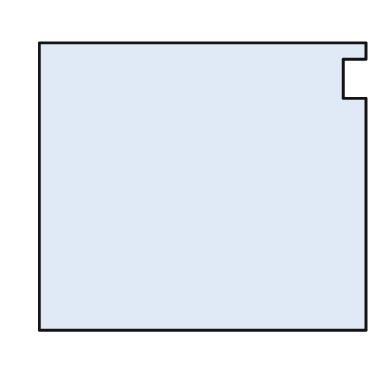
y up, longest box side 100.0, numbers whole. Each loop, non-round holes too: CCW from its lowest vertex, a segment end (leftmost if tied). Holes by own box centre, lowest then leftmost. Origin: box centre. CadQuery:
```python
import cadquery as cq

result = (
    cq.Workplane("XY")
    .moveTo(-50.0, -44.0)
    .lineTo(50.0, -44.0)
    .lineTo(50.0, 27.0)
    .lineTo(43.0, 27.0)
    .lineTo(43.0, 39.0)
    .lineTo(50.0, 39.0)
    .lineTo(50.0, 44.0)
    .lineTo(-50.0, 44.0)
    .close()
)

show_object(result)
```